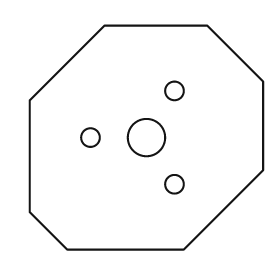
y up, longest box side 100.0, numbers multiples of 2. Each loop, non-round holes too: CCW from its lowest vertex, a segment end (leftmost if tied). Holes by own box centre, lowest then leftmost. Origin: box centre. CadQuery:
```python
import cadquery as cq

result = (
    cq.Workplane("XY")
    .moveTo(-34.0, -48.0)
    .lineTo(16.0, -48.0)
    .lineTo(50.0, -14.0)
    .lineTo(50.0, 24.0)
    .lineTo(26.0, 48.0)
    .lineTo(-18.0, 48.0)
    .lineTo(-50.0, 16.0)
    .lineTo(-50.0, -32.0)
    .close()
    .moveTo(12.0, -20.0)
    .circle(4.0)
    .moveTo(-24.0, 0.0)
    .circle(4.0)
    .moveTo(0.0, 0.0)
    .circle(8.0)
    .moveTo(12.0, 20.0)
    .circle(4.0)
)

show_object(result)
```